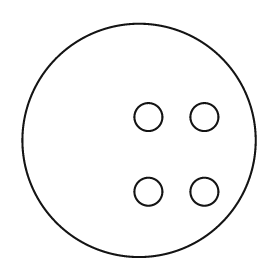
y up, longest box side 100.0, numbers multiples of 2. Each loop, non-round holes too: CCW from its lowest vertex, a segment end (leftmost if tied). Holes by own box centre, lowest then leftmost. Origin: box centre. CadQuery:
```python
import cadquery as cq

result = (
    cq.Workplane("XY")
    .moveTo(0.0, 0.0)
    .circle(50.0)
    .moveTo(4.0, -22.0)
    .circle(6.0)
    .moveTo(28.0, -22.0)
    .circle(6.0)
    .moveTo(4.0, 10.0)
    .circle(6.0)
    .moveTo(28.0, 10.0)
    .circle(6.0)
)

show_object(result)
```